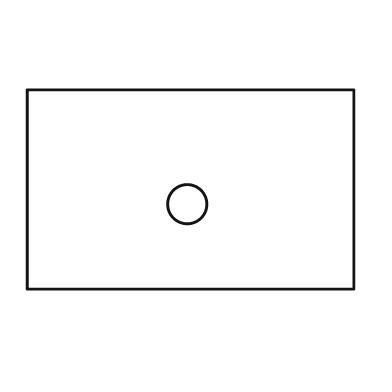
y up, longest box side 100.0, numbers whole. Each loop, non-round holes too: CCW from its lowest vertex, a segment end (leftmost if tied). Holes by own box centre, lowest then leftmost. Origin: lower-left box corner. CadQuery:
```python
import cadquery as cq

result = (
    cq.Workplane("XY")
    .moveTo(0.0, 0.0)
    .lineTo(100.0, 0.0)
    .lineTo(100.0, 61.0)
    .lineTo(0.0, 61.0)
    .close()
    .moveTo(49.0, 26.0)
    .circle(6.0)
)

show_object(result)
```